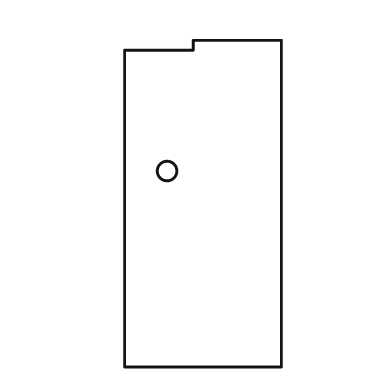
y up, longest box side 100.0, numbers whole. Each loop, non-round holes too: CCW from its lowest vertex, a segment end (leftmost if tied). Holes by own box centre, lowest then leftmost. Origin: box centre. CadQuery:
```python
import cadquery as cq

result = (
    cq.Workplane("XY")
    .moveTo(-24.0, -50.0)
    .lineTo(24.0, -50.0)
    .lineTo(24.0, 50.0)
    .lineTo(-3.0, 50.0)
    .lineTo(-3.0, 47.0)
    .lineTo(-24.0, 47.0)
    .close()
    .moveTo(-11.0, 10.0)
    .circle(3.0)
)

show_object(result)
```